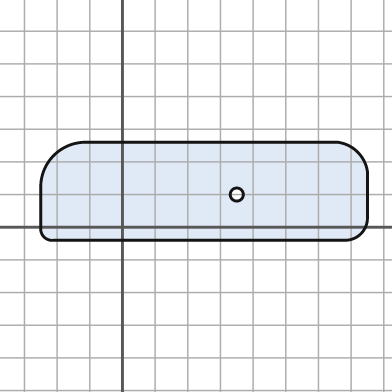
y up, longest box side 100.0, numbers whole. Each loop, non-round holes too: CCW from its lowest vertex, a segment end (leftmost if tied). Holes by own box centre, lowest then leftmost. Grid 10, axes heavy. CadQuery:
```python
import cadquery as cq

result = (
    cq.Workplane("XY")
    .moveTo(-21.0, -4.0)
    .lineTo(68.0, -4.0)
    .threePointArc((73.0, -2.0), (75.0, 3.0))
    .lineTo(75.0, 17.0)
    .threePointArc((72.0, 23.0), (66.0, 26.0))
    .lineTo(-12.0, 26.0)
    .threePointArc((-21.0, 22.0), (-25.0, 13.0))
    .lineTo(-25.0, 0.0)
    .threePointArc((-24.0, -3.0), (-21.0, -4.0))
    .close()
    .moveTo(35.0, 10.0)
    .circle(2.0)
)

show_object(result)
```